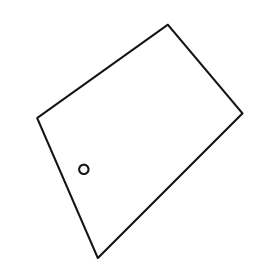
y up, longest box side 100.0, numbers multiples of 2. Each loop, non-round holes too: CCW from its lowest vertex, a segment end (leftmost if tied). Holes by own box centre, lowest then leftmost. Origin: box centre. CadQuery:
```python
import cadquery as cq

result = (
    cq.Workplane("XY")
    .moveTo(-18.0, -50.0)
    .lineTo(44.0, 12.0)
    .lineTo(12.0, 50.0)
    .lineTo(-44.0, 10.0)
    .close()
    .moveTo(-24.0, -12.0)
    .circle(2.0)
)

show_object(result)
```